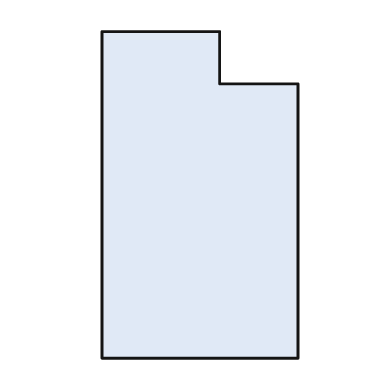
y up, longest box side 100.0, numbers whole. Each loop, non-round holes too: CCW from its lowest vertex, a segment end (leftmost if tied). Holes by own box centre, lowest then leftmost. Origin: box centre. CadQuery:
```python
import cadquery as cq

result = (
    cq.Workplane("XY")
    .moveTo(-30.0, -50.0)
    .lineTo(30.0, -50.0)
    .lineTo(30.0, 34.0)
    .lineTo(6.0, 34.0)
    .lineTo(6.0, 50.0)
    .lineTo(-30.0, 50.0)
    .close()
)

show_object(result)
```